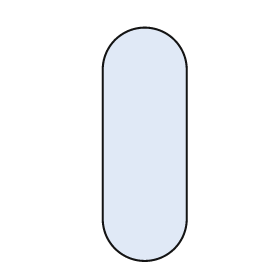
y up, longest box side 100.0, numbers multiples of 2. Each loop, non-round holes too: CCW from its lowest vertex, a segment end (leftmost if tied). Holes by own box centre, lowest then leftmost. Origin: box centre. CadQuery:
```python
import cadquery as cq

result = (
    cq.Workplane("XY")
    .moveTo(-18.0, -32.0)
    .threePointArc((0.0, -50.0), (18.0, -32.0))
    .lineTo(18.0, 32.0)
    .threePointArc((0.0, 50.0), (-18.0, 32.0))
    .close()
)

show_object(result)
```